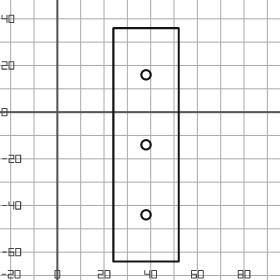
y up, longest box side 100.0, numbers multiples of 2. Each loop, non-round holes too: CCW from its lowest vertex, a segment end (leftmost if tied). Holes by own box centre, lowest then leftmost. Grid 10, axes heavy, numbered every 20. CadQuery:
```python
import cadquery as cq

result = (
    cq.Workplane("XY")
    .moveTo(24.0, -64.0)
    .lineTo(52.0, -64.0)
    .lineTo(52.0, 36.0)
    .lineTo(24.0, 36.0)
    .close()
    .moveTo(38.0, -44.0)
    .circle(2.0)
    .moveTo(38.0, -14.0)
    .circle(2.0)
    .moveTo(38.0, 16.0)
    .circle(2.0)
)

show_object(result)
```